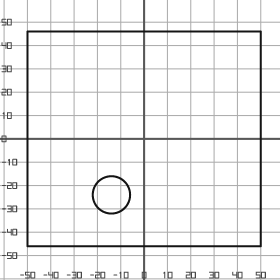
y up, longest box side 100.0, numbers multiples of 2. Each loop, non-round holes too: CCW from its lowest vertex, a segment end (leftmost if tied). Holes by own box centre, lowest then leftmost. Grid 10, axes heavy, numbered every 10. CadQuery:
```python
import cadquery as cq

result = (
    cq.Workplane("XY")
    .moveTo(-50.0, -46.0)
    .lineTo(50.0, -46.0)
    .lineTo(50.0, 46.0)
    .lineTo(-50.0, 46.0)
    .close()
    .moveTo(-14.0, -24.0)
    .circle(8.0)
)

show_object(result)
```